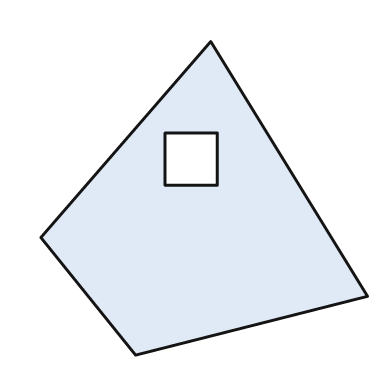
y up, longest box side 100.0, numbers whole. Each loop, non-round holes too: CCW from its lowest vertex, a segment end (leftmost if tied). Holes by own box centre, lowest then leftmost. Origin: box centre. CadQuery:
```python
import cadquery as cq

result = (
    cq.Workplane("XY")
    .moveTo(-21.0, -48.0)
    .lineTo(50.0, -30.0)
    .lineTo(2.0, 48.0)
    .lineTo(-50.0, -12.0)
    .close()
    .moveTo(-12.0, 4.0)
    .lineTo(4.0, 4.0)
    .lineTo(4.0, 20.0)
    .lineTo(-12.0, 20.0)
    .close()
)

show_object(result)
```